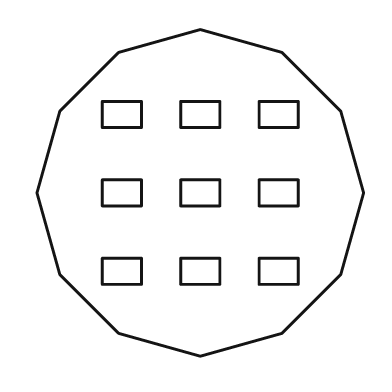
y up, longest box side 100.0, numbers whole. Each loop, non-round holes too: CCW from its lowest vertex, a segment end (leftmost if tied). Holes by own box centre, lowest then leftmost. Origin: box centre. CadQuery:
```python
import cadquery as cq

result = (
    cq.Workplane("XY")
    .moveTo(0.0, -50.0)
    .lineTo(25.0, -43.0)
    .lineTo(43.0, -25.0)
    .lineTo(50.0, 0.0)
    .lineTo(43.0, 25.0)
    .lineTo(25.0, 43.0)
    .lineTo(0.0, 50.0)
    .lineTo(-25.0, 43.0)
    .lineTo(-43.0, 25.0)
    .lineTo(-50.0, 0.0)
    .lineTo(-43.0, -25.0)
    .lineTo(-25.0, -43.0)
    .close()
    .moveTo(-30.0, -28.0)
    .lineTo(-18.0, -28.0)
    .lineTo(-18.0, -20.0)
    .lineTo(-30.0, -20.0)
    .close()
    .moveTo(-6.0, -28.0)
    .lineTo(6.0, -28.0)
    .lineTo(6.0, -20.0)
    .lineTo(-6.0, -20.0)
    .close()
    .moveTo(18.0, -28.0)
    .lineTo(30.0, -28.0)
    .lineTo(30.0, -20.0)
    .lineTo(18.0, -20.0)
    .close()
    .moveTo(-30.0, -4.0)
    .lineTo(-18.0, -4.0)
    .lineTo(-18.0, 4.0)
    .lineTo(-30.0, 4.0)
    .close()
    .moveTo(-6.0, -4.0)
    .lineTo(6.0, -4.0)
    .lineTo(6.0, 4.0)
    .lineTo(-6.0, 4.0)
    .close()
    .moveTo(18.0, -4.0)
    .lineTo(30.0, -4.0)
    .lineTo(30.0, 4.0)
    .lineTo(18.0, 4.0)
    .close()
    .moveTo(-30.0, 20.0)
    .lineTo(-18.0, 20.0)
    .lineTo(-18.0, 28.0)
    .lineTo(-30.0, 28.0)
    .close()
    .moveTo(-6.0, 20.0)
    .lineTo(6.0, 20.0)
    .lineTo(6.0, 28.0)
    .lineTo(-6.0, 28.0)
    .close()
    .moveTo(18.0, 20.0)
    .lineTo(30.0, 20.0)
    .lineTo(30.0, 28.0)
    .lineTo(18.0, 28.0)
    .close()
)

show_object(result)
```